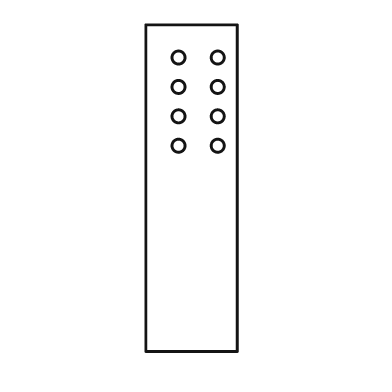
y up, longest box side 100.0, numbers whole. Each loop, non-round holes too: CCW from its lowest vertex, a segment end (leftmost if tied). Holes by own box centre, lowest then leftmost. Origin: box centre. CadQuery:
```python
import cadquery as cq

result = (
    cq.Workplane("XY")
    .moveTo(-14.0, -50.0)
    .lineTo(14.0, -50.0)
    .lineTo(14.0, 50.0)
    .lineTo(-14.0, 50.0)
    .close()
    .moveTo(-4.0, 13.0)
    .circle(2.0)
    .moveTo(8.0, 13.0)
    .circle(2.0)
    .moveTo(-4.0, 22.0)
    .circle(2.0)
    .moveTo(8.0, 22.0)
    .circle(2.0)
    .moveTo(-4.0, 31.0)
    .circle(2.0)
    .moveTo(8.0, 31.0)
    .circle(2.0)
    .moveTo(-4.0, 40.0)
    .circle(2.0)
    .moveTo(8.0, 40.0)
    .circle(2.0)
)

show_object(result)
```